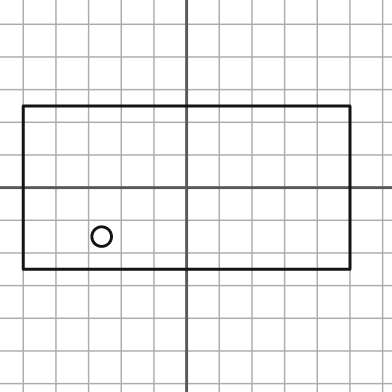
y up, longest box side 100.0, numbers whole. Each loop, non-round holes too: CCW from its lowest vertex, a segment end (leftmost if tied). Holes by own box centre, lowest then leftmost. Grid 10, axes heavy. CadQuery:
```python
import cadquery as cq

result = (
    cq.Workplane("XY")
    .moveTo(-50.0, -25.0)
    .lineTo(50.0, -25.0)
    .lineTo(50.0, 25.0)
    .lineTo(-50.0, 25.0)
    .close()
    .moveTo(-26.0, -15.0)
    .circle(3.0)
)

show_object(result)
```